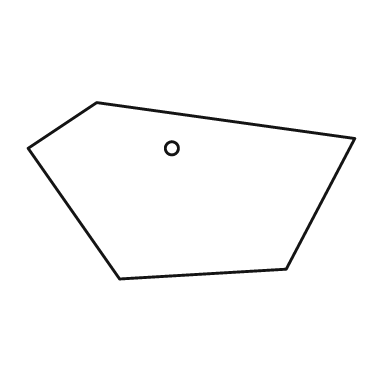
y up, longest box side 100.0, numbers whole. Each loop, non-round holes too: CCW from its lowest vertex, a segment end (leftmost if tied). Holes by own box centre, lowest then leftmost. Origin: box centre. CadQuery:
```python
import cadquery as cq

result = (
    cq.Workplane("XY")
    .moveTo(-22.0, -27.0)
    .lineTo(29.0, -24.0)
    .lineTo(50.0, 16.0)
    .lineTo(-29.0, 27.0)
    .lineTo(-50.0, 13.0)
    .close()
    .moveTo(-6.0, 13.0)
    .circle(2.0)
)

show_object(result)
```